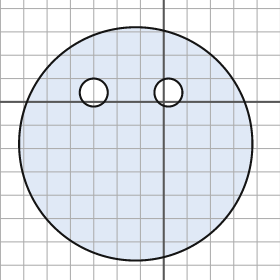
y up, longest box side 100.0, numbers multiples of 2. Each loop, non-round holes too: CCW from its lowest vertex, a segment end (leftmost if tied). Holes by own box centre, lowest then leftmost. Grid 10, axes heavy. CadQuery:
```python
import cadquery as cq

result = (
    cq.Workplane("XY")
    .moveTo(-12.0, -18.0)
    .circle(50.0)
    .moveTo(-30.0, 4.0)
    .circle(6.0)
    .moveTo(2.0, 4.0)
    .circle(6.0)
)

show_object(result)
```